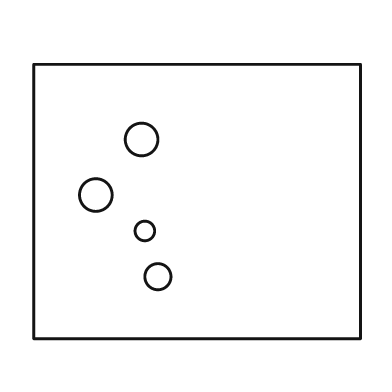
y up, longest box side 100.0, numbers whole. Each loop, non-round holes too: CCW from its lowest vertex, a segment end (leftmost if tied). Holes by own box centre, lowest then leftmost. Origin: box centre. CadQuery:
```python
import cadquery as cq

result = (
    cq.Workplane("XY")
    .moveTo(-50.0, -42.0)
    .lineTo(50.0, -42.0)
    .lineTo(50.0, 42.0)
    .lineTo(-50.0, 42.0)
    .close()
    .moveTo(-12.0, -23.0)
    .circle(4.0)
    .moveTo(-16.0, -9.0)
    .circle(3.0)
    .moveTo(-31.0, 2.0)
    .circle(5.0)
    .moveTo(-17.0, 19.0)
    .circle(5.0)
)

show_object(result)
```